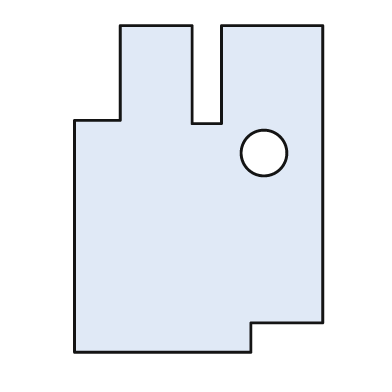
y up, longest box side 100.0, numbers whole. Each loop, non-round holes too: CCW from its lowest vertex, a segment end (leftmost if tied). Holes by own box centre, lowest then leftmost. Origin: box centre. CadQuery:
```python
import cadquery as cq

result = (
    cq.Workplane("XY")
    .moveTo(-38.0, -50.0)
    .lineTo(16.0, -50.0)
    .lineTo(16.0, -41.0)
    .lineTo(38.0, -41.0)
    .lineTo(38.0, 50.0)
    .lineTo(7.0, 50.0)
    .lineTo(7.0, 20.0)
    .lineTo(-2.0, 20.0)
    .lineTo(-2.0, 50.0)
    .lineTo(-24.0, 50.0)
    .lineTo(-24.0, 21.0)
    .lineTo(-38.0, 21.0)
    .close()
    .moveTo(20.0, 11.0)
    .circle(7.0)
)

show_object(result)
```